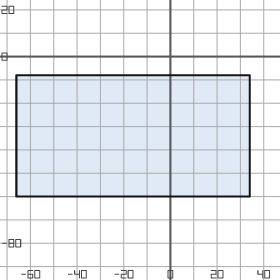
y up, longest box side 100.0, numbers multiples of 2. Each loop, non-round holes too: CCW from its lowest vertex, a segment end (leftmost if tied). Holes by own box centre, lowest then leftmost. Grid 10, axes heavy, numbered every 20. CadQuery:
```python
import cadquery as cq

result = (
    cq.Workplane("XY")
    .moveTo(-66.0, -60.0)
    .lineTo(34.0, -60.0)
    .lineTo(34.0, -8.0)
    .lineTo(-66.0, -8.0)
    .close()
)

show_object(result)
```